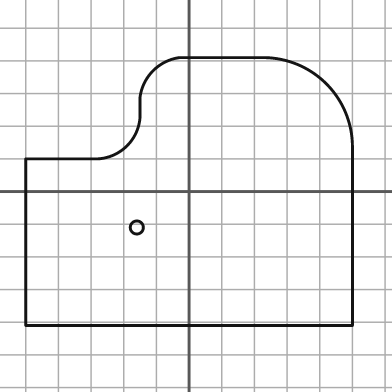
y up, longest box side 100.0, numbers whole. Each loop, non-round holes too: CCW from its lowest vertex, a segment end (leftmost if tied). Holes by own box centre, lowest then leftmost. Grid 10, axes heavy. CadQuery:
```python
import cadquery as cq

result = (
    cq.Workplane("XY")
    .moveTo(-50.0, -41.0)
    .lineTo(50.0, -41.0)
    .lineTo(50.0, 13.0)
    .threePointArc((42.0, 33.0), (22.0, 41.0))
    .lineTo(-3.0, 41.0)
    .threePointArc((-11.0, 37.0), (-15.0, 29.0))
    .lineTo(-15.0, 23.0)
    .threePointArc((-19.0, 14.0), (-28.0, 10.0))
    .lineTo(-50.0, 10.0)
    .close()
    .moveTo(-16.0, -11.0)
    .circle(2.0)
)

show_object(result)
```